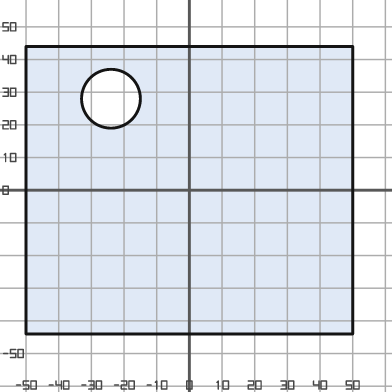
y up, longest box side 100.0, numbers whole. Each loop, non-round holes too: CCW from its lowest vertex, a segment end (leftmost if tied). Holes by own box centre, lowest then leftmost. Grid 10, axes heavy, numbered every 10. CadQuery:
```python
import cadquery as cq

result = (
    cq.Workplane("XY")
    .moveTo(-50.0, -44.0)
    .lineTo(50.0, -44.0)
    .lineTo(50.0, 44.0)
    .lineTo(-50.0, 44.0)
    .close()
    .moveTo(-24.0, 28.0)
    .circle(9.0)
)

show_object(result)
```